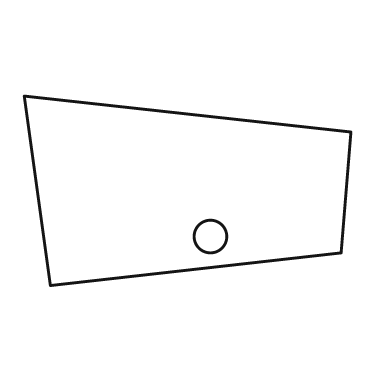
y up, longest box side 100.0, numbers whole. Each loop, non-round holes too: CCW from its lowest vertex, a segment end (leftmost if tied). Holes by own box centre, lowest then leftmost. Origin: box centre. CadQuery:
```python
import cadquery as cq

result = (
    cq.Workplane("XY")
    .moveTo(-42.0, -29.0)
    .lineTo(47.0, -19.0)
    .lineTo(50.0, 18.0)
    .lineTo(-50.0, 29.0)
    .close()
    .moveTo(7.0, -14.0)
    .circle(5.0)
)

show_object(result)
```